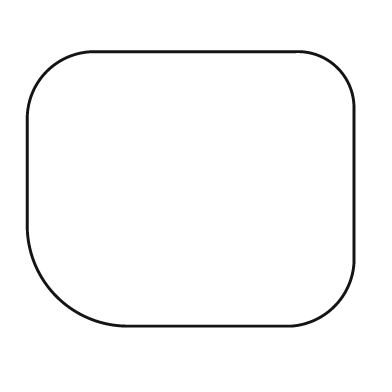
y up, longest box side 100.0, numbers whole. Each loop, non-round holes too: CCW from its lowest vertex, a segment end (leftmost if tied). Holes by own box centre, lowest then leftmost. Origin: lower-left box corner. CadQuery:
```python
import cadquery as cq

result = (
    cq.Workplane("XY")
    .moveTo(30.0, 0.0)
    .lineTo(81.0, 0.0)
    .threePointArc((94.0, 6.0), (100.0, 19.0))
    .lineTo(100.0, 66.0)
    .threePointArc((95.0, 79.0), (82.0, 84.0))
    .lineTo(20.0, 84.0)
    .threePointArc((6.0, 78.0), (0.0, 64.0))
    .lineTo(0.0, 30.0)
    .threePointArc((9.0, 9.0), (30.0, 0.0))
    .close()
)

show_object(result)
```